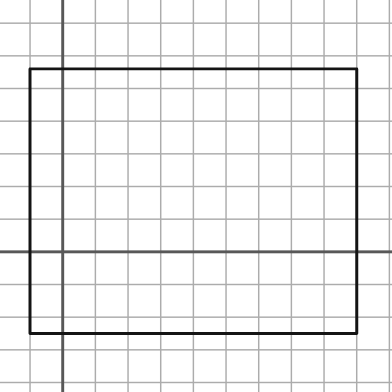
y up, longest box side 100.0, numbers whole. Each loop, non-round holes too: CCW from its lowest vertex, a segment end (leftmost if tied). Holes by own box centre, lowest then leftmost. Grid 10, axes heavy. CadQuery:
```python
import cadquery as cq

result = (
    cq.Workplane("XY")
    .moveTo(-10.0, -25.0)
    .lineTo(90.0, -25.0)
    .lineTo(90.0, 56.0)
    .lineTo(-10.0, 56.0)
    .close()
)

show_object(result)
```